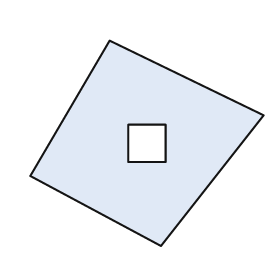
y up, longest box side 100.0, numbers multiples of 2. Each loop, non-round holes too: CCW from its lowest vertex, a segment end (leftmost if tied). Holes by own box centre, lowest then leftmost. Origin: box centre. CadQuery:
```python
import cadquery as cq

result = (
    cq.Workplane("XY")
    .moveTo(6.0, -44.0)
    .lineTo(50.0, 12.0)
    .lineTo(-16.0, 44.0)
    .lineTo(-50.0, -14.0)
    .close()
    .moveTo(-8.0, -8.0)
    .lineTo(8.0, -8.0)
    .lineTo(8.0, 8.0)
    .lineTo(-8.0, 8.0)
    .close()
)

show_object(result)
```